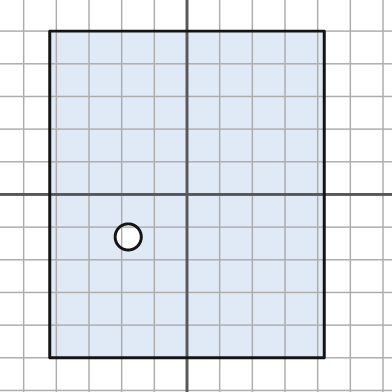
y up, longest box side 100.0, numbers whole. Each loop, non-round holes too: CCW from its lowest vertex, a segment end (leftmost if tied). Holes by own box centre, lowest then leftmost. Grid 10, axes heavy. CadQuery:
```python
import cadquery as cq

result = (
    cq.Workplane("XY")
    .moveTo(-42.0, -50.0)
    .lineTo(42.0, -50.0)
    .lineTo(42.0, 50.0)
    .lineTo(-42.0, 50.0)
    .close()
    .moveTo(-18.0, -13.0)
    .circle(4.0)
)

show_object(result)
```